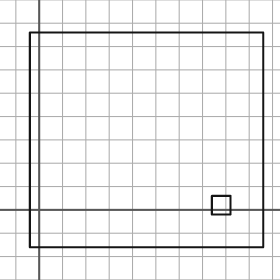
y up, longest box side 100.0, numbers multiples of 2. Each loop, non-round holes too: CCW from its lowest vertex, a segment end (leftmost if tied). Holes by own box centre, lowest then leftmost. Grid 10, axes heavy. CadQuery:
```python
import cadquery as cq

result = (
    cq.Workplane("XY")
    .moveTo(-4.0, -16.0)
    .lineTo(96.0, -16.0)
    .lineTo(96.0, 76.0)
    .lineTo(-4.0, 76.0)
    .close()
    .moveTo(74.0, -2.0)
    .lineTo(82.0, -2.0)
    .lineTo(82.0, 6.0)
    .lineTo(74.0, 6.0)
    .close()
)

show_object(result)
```